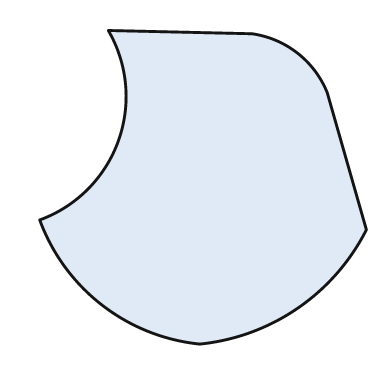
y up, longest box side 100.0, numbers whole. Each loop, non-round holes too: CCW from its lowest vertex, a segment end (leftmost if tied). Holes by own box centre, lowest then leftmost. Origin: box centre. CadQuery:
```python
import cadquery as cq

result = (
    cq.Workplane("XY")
    .moveTo(-1.0, -48.0)
    .threePointArc((29.0, -37.0), (50.0, -13.0))
    .lineTo(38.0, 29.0)
    .threePointArc((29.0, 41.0), (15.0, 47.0))
    .lineTo(-29.0, 48.0)
    .threePointArc((-26.0, 14.0), (-50.0, -10.0))
    .threePointArc((-31.0, -36.0), (-1.0, -48.0))
    .close()
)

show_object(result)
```